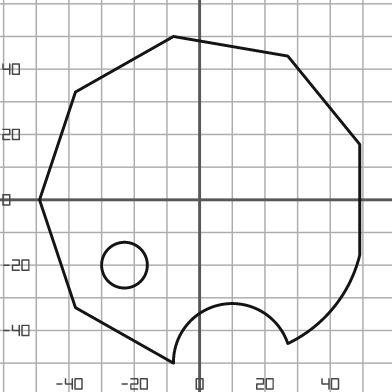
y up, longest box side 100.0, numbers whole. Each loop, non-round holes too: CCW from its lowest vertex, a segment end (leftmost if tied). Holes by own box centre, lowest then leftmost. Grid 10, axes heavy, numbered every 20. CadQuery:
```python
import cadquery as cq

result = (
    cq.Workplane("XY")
    .moveTo(-8.0, -50.0)
    .threePointArc((7.0, -32.0), (27.0, -44.0))
    .threePointArc((41.0, -33.0), (49.0, -17.0))
    .lineTo(49.0, 17.0)
    .lineTo(27.0, 44.0)
    .lineTo(-8.0, 50.0)
    .lineTo(-38.0, 33.0)
    .lineTo(-49.0, 0.0)
    .lineTo(-38.0, -33.0)
    .close()
    .moveTo(-23.0, -20.0)
    .circle(7.0)
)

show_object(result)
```